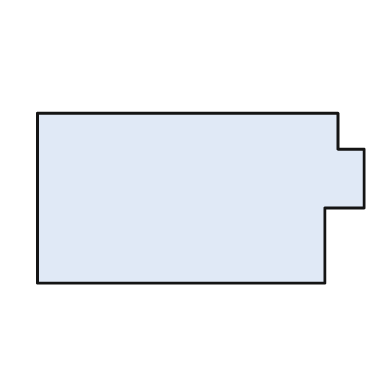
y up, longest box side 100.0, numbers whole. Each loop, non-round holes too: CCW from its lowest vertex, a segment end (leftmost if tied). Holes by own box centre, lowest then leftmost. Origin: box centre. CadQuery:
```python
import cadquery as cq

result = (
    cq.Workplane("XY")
    .moveTo(-50.0, -26.0)
    .lineTo(38.0, -26.0)
    .lineTo(38.0, -3.0)
    .lineTo(50.0, -3.0)
    .lineTo(50.0, 15.0)
    .lineTo(42.0, 15.0)
    .lineTo(42.0, 26.0)
    .lineTo(-50.0, 26.0)
    .close()
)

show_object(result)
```